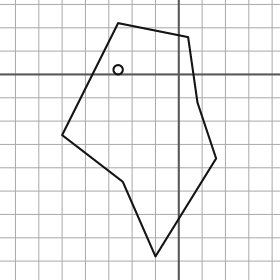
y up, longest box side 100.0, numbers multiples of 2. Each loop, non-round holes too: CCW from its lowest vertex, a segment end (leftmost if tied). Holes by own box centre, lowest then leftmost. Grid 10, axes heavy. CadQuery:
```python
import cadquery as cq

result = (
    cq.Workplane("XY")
    .moveTo(-10.0, -78.0)
    .lineTo(16.0, -36.0)
    .lineTo(8.0, -12.0)
    .lineTo(4.0, 16.0)
    .lineTo(-26.0, 22.0)
    .lineTo(-50.0, -26.0)
    .lineTo(-24.0, -46.0)
    .close()
    .moveTo(-26.0, 2.0)
    .circle(2.0)
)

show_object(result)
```